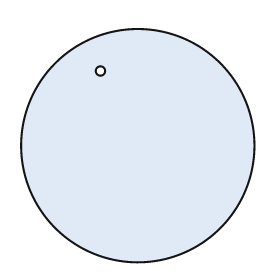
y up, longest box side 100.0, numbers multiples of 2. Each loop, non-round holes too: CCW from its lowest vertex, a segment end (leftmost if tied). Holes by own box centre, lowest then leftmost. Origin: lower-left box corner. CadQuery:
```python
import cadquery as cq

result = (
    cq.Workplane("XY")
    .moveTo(50.0, 50.0)
    .circle(50.0)
    .moveTo(34.0, 82.0)
    .circle(2.0)
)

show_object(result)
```